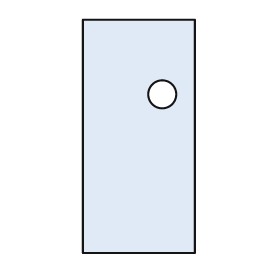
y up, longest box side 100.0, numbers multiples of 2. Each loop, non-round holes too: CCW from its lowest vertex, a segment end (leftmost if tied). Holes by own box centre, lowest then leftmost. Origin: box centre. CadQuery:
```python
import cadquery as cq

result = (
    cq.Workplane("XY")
    .moveTo(-24.0, -50.0)
    .lineTo(24.0, -50.0)
    .lineTo(24.0, 50.0)
    .lineTo(-24.0, 50.0)
    .close()
    .moveTo(10.0, 18.0)
    .circle(6.0)
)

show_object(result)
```